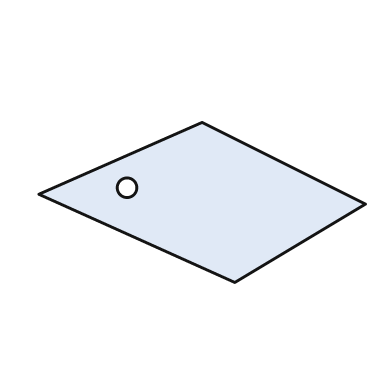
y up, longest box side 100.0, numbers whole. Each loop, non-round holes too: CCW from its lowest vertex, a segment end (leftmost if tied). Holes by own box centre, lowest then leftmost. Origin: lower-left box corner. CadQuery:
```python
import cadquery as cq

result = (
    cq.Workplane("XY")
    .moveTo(60.0, 0.0)
    .lineTo(100.0, 24.0)
    .lineTo(50.0, 49.0)
    .lineTo(0.0, 27.0)
    .close()
    .moveTo(27.0, 29.0)
    .circle(3.0)
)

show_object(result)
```